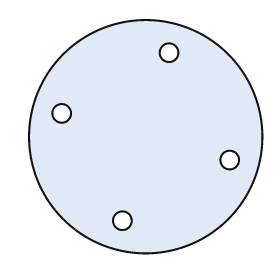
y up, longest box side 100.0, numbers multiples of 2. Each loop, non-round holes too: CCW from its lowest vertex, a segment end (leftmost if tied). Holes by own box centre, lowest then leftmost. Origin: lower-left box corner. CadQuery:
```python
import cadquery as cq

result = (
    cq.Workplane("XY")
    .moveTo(50.0, 50.0)
    .circle(50.0)
    .moveTo(40.0, 14.0)
    .circle(4.0)
    .moveTo(86.0, 40.0)
    .circle(4.0)
    .moveTo(14.0, 60.0)
    .circle(4.0)
    .moveTo(60.0, 86.0)
    .circle(4.0)
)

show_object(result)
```